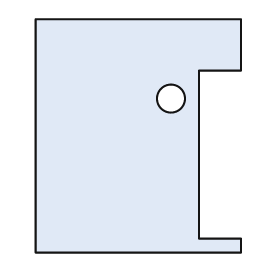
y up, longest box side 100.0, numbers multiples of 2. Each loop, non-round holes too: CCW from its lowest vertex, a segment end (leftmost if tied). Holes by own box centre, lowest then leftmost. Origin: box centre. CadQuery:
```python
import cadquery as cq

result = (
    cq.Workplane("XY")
    .moveTo(-44.0, -50.0)
    .lineTo(44.0, -50.0)
    .lineTo(44.0, -44.0)
    .lineTo(26.0, -44.0)
    .lineTo(26.0, 28.0)
    .lineTo(44.0, 28.0)
    .lineTo(44.0, 50.0)
    .lineTo(-44.0, 50.0)
    .close()
    .moveTo(14.0, 16.0)
    .circle(6.0)
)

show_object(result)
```